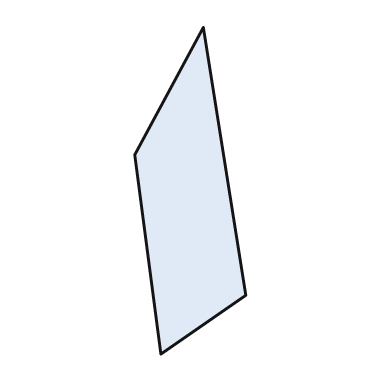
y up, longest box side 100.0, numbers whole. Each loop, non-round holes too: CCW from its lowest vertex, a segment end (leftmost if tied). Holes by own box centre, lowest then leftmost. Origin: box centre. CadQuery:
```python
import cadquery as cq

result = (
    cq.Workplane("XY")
    .moveTo(-9.0, -50.0)
    .lineTo(17.0, -32.0)
    .lineTo(4.0, 50.0)
    .lineTo(-17.0, 11.0)
    .close()
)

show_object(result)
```